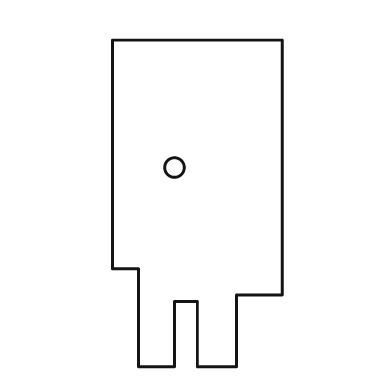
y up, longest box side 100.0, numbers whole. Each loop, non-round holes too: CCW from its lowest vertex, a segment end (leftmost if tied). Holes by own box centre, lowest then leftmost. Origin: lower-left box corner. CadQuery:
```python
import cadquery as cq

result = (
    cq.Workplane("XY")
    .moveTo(8.0, 0.0)
    .lineTo(19.0, 0.0)
    .lineTo(19.0, 20.0)
    .lineTo(26.0, 20.0)
    .lineTo(26.0, 0.0)
    .lineTo(38.0, 0.0)
    .lineTo(38.0, 22.0)
    .lineTo(52.0, 22.0)
    .lineTo(52.0, 100.0)
    .lineTo(0.0, 100.0)
    .lineTo(0.0, 30.0)
    .lineTo(8.0, 30.0)
    .close()
    .moveTo(19.0, 61.0)
    .circle(3.0)
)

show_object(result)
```